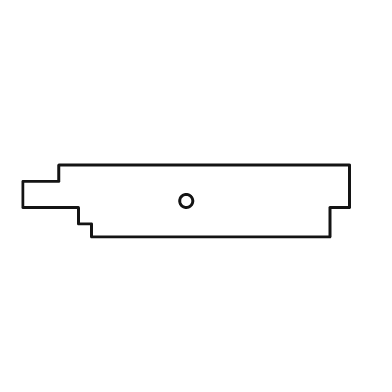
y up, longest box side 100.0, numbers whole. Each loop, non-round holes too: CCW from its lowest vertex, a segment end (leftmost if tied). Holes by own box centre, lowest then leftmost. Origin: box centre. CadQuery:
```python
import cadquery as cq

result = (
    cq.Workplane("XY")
    .moveTo(-29.0, -11.0)
    .lineTo(44.0, -11.0)
    .lineTo(44.0, -2.0)
    .lineTo(50.0, -2.0)
    .lineTo(50.0, 11.0)
    .lineTo(-39.0, 11.0)
    .lineTo(-39.0, 6.0)
    .lineTo(-50.0, 6.0)
    .lineTo(-50.0, -2.0)
    .lineTo(-33.0, -2.0)
    .lineTo(-33.0, -7.0)
    .lineTo(-29.0, -7.0)
    .close()
    .moveTo(0.0, 0.0)
    .circle(2.0)
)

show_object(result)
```